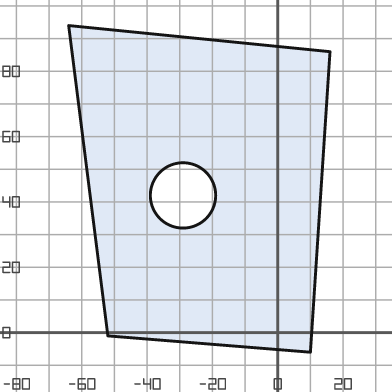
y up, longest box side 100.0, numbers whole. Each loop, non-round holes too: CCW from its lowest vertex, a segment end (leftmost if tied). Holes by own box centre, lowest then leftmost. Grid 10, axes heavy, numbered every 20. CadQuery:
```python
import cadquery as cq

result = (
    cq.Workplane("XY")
    .moveTo(10.0, -6.0)
    .lineTo(16.0, 86.0)
    .lineTo(-64.0, 94.0)
    .lineTo(-52.0, -1.0)
    .close()
    .moveTo(-29.0, 42.0)
    .circle(10.0)
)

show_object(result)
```